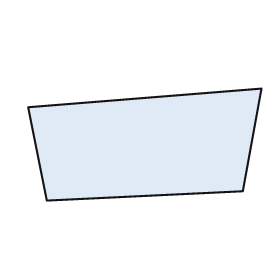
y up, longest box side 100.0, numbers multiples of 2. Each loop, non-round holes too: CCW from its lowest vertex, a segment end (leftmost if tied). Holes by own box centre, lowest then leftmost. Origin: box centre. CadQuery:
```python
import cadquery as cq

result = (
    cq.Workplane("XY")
    .moveTo(-42.0, -24.0)
    .lineTo(42.0, -20.0)
    .lineTo(50.0, 24.0)
    .lineTo(-50.0, 16.0)
    .close()
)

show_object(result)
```